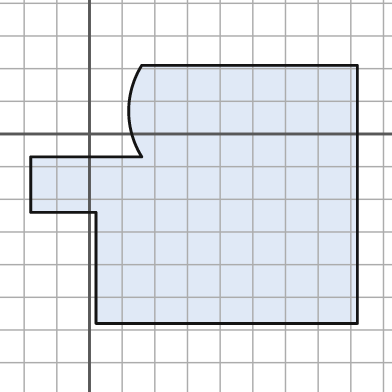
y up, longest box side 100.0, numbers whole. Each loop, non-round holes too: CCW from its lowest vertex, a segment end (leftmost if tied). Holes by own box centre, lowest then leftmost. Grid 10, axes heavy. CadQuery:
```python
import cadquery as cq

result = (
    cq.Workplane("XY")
    .moveTo(2.0, -58.0)
    .lineTo(82.0, -58.0)
    .lineTo(82.0, 21.0)
    .lineTo(16.0, 21.0)
    .threePointArc((12.0, 7.0), (16.0, -7.0))
    .lineTo(-18.0, -7.0)
    .lineTo(-18.0, -24.0)
    .lineTo(2.0, -24.0)
    .close()
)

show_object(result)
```